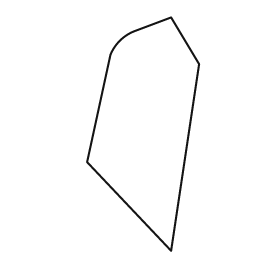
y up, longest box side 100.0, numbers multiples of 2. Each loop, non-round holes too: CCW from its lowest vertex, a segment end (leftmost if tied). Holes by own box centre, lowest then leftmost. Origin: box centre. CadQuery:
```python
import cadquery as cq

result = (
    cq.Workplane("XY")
    .moveTo(12.0, -50.0)
    .lineTo(24.0, 30.0)
    .lineTo(12.0, 50.0)
    .lineTo(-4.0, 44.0)
    .threePointArc((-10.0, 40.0), (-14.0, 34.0))
    .lineTo(-24.0, -12.0)
    .close()
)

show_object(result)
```